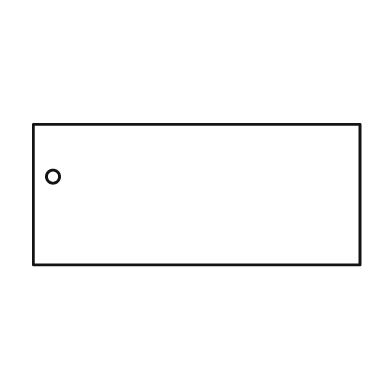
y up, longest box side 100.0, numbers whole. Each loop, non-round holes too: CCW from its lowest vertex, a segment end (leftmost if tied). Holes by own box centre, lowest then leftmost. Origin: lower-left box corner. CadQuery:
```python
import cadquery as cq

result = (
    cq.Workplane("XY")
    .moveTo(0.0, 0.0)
    .lineTo(100.0, 0.0)
    .lineTo(100.0, 43.0)
    .lineTo(0.0, 43.0)
    .close()
    .moveTo(6.0, 27.0)
    .circle(2.0)
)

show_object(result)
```